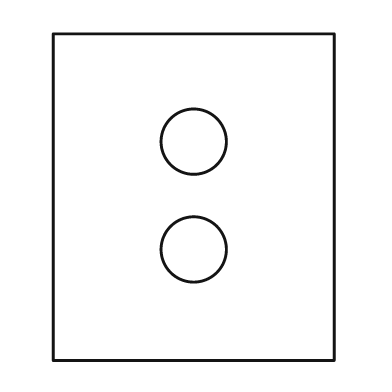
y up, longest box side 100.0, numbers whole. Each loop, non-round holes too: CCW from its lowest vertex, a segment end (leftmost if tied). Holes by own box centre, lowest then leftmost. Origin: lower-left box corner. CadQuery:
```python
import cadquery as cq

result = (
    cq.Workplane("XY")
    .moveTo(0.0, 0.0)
    .lineTo(86.0, 0.0)
    .lineTo(86.0, 100.0)
    .lineTo(0.0, 100.0)
    .close()
    .moveTo(43.0, 34.0)
    .circle(10.0)
    .moveTo(43.0, 67.0)
    .circle(10.0)
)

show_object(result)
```